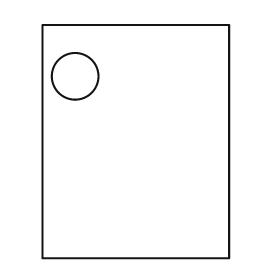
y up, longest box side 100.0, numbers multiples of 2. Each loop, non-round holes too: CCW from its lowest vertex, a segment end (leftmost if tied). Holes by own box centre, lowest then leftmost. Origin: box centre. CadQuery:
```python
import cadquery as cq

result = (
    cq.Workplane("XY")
    .moveTo(-40.0, -50.0)
    .lineTo(40.0, -50.0)
    .lineTo(40.0, 50.0)
    .lineTo(-40.0, 50.0)
    .close()
    .moveTo(-26.0, 28.0)
    .circle(10.0)
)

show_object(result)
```